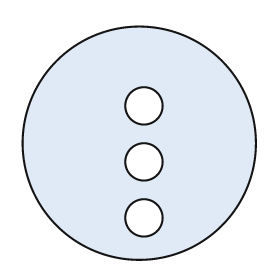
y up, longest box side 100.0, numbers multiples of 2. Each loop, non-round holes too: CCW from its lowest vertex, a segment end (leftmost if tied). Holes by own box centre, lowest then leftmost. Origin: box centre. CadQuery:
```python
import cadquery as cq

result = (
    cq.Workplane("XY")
    .moveTo(0.0, 0.0)
    .circle(50.0)
    .moveTo(2.0, -32.0)
    .circle(8.0)
    .moveTo(2.0, -8.0)
    .circle(8.0)
    .moveTo(2.0, 16.0)
    .circle(8.0)
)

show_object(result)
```